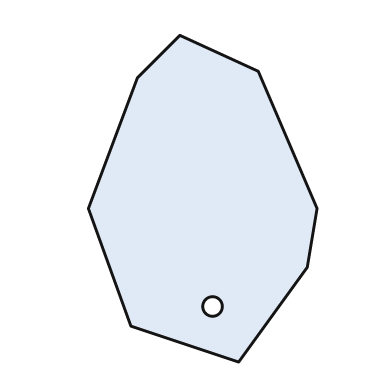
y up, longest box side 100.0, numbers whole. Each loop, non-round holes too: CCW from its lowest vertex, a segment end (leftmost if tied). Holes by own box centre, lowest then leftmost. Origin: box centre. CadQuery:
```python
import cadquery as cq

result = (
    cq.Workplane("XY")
    .moveTo(11.0, -50.0)
    .lineTo(32.0, -21.0)
    .lineTo(35.0, -3.0)
    .lineTo(17.0, 39.0)
    .lineTo(-7.0, 50.0)
    .lineTo(-20.0, 37.0)
    .lineTo(-35.0, -3.0)
    .lineTo(-22.0, -39.0)
    .close()
    .moveTo(3.0, -33.0)
    .circle(3.0)
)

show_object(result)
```